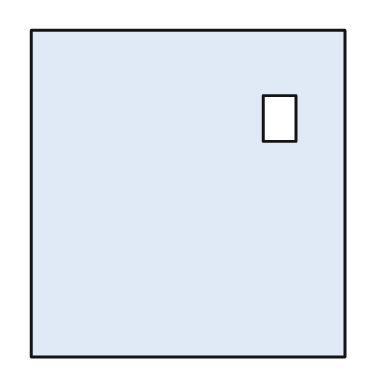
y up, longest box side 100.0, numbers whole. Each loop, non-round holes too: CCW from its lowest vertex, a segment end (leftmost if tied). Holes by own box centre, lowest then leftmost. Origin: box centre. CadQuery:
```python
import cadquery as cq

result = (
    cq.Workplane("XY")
    .moveTo(-48.0, -50.0)
    .lineTo(48.0, -50.0)
    .lineTo(48.0, 50.0)
    .lineTo(-48.0, 50.0)
    .close()
    .moveTo(23.0, 16.0)
    .lineTo(33.0, 16.0)
    .lineTo(33.0, 30.0)
    .lineTo(23.0, 30.0)
    .close()
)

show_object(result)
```